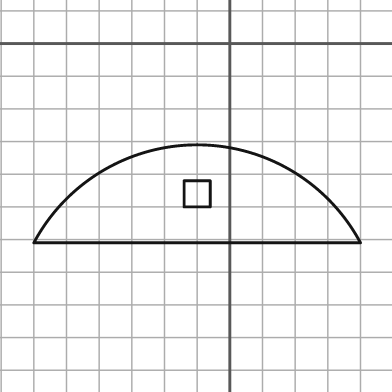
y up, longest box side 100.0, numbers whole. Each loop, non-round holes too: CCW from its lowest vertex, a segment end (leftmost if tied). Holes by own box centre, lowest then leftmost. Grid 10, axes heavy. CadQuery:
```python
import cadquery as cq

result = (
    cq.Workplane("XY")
    .moveTo(-60.0, -61.0)
    .lineTo(40.0, -61.0)
    .threePointArc((-10.0, -31.0), (-60.0, -61.0))
    .close()
    .moveTo(-14.0, -50.0)
    .lineTo(-6.0, -50.0)
    .lineTo(-6.0, -42.0)
    .lineTo(-14.0, -42.0)
    .close()
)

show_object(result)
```